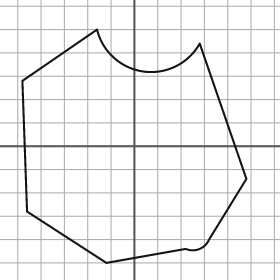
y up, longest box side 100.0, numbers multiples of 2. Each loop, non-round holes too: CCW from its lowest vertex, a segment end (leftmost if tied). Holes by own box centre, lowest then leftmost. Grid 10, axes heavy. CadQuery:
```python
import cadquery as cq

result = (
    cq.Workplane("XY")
    .moveTo(-12.0, -50.0)
    .lineTo(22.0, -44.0)
    .threePointArc((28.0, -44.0), (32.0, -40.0))
    .lineTo(48.0, -14.0)
    .lineTo(28.0, 44.0)
    .threePointArc((4.0, 32.0), (-16.0, 50.0))
    .lineTo(-48.0, 28.0)
    .lineTo(-46.0, -28.0)
    .close()
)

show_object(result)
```